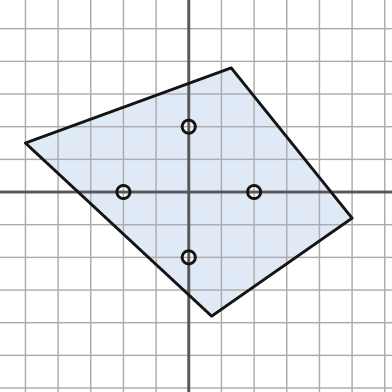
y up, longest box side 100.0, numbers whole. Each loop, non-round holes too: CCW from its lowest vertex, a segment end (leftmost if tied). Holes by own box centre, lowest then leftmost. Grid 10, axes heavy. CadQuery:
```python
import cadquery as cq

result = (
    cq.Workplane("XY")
    .moveTo(7.0, -38.0)
    .lineTo(50.0, -8.0)
    .lineTo(13.0, 38.0)
    .lineTo(-50.0, 15.0)
    .close()
    .moveTo(0.0, -20.0)
    .circle(2.0)
    .moveTo(-20.0, 0.0)
    .circle(2.0)
    .moveTo(20.0, 0.0)
    .circle(2.0)
    .moveTo(0.0, 20.0)
    .circle(2.0)
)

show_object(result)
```